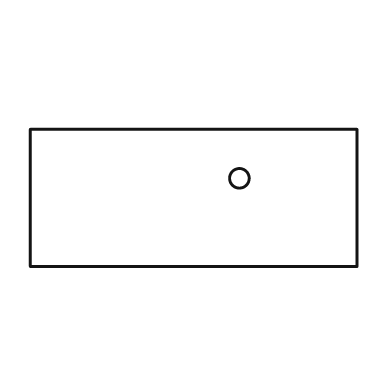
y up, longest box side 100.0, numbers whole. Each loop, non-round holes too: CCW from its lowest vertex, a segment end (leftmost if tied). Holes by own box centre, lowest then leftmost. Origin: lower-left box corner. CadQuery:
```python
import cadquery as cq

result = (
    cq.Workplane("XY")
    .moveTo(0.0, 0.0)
    .lineTo(100.0, 0.0)
    .lineTo(100.0, 42.0)
    .lineTo(0.0, 42.0)
    .close()
    .moveTo(64.0, 27.0)
    .circle(3.0)
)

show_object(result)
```